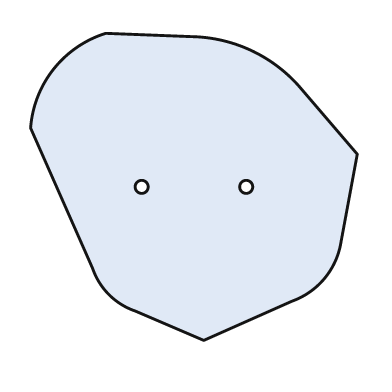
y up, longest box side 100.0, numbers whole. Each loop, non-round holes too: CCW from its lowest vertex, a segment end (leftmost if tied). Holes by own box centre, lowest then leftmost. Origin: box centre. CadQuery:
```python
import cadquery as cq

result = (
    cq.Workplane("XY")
    .moveTo(3.0, -47.0)
    .lineTo(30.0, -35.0)
    .threePointArc((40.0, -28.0), (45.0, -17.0))
    .lineTo(50.0, 10.0)
    .lineTo(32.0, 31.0)
    .threePointArc((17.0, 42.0), (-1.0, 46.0))
    .lineTo(-27.0, 47.0)
    .threePointArc((-43.0, 36.0), (-50.0, 18.0))
    .lineTo(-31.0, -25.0)
    .threePointArc((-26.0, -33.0), (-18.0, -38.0))
    .close()
    .moveTo(-16.0, 0.0)
    .circle(2.0)
    .moveTo(16.0, 0.0)
    .circle(2.0)
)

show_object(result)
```